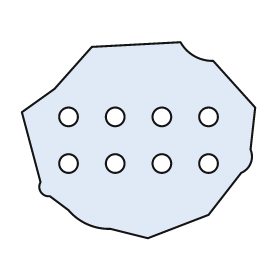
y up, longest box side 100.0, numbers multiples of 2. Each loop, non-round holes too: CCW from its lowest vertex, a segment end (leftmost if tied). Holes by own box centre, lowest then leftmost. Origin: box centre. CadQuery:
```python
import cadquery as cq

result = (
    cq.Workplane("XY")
    .moveTo(4.0, -42.0)
    .lineTo(30.0, -32.0)
    .lineTo(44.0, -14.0)
    .threePointArc((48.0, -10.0), (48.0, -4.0))
    .lineTo(50.0, 14.0)
    .lineTo(32.0, 34.0)
    .threePointArc((24.0, 36.0), (18.0, 42.0))
    .lineTo(-20.0, 40.0)
    .lineTo(-36.0, 22.0)
    .lineTo(-50.0, 12.0)
    .lineTo(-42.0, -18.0)
    .threePointArc((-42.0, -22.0), (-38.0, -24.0))
    .lineTo(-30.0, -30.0)
    .threePointArc((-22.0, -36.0), (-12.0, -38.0))
    .close()
    .moveTo(-30.0, -10.0)
    .circle(4.0)
    .moveTo(-10.0, -10.0)
    .circle(4.0)
    .moveTo(10.0, -10.0)
    .circle(4.0)
    .moveTo(30.0, -10.0)
    .circle(4.0)
    .moveTo(-30.0, 10.0)
    .circle(4.0)
    .moveTo(-10.0, 10.0)
    .circle(4.0)
    .moveTo(10.0, 10.0)
    .circle(4.0)
    .moveTo(30.0, 10.0)
    .circle(4.0)
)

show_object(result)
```